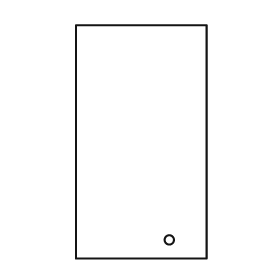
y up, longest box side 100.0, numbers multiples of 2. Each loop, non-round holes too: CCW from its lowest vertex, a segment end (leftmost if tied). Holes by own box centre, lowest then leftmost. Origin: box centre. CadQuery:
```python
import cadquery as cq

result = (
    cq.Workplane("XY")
    .moveTo(-28.0, -50.0)
    .lineTo(28.0, -50.0)
    .lineTo(28.0, 50.0)
    .lineTo(-28.0, 50.0)
    .close()
    .moveTo(12.0, -42.0)
    .circle(2.0)
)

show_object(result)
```